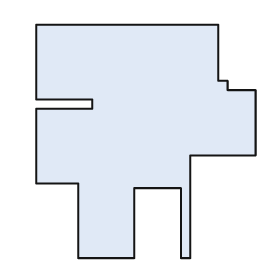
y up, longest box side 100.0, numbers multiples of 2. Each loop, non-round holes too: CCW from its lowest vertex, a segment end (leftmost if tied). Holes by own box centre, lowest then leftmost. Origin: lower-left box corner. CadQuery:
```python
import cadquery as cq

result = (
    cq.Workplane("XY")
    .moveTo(18.0, 0.0)
    .lineTo(42.0, 0.0)
    .lineTo(42.0, 30.0)
    .lineTo(62.0, 30.0)
    .lineTo(62.0, 0.0)
    .lineTo(66.0, 0.0)
    .lineTo(66.0, 44.0)
    .lineTo(94.0, 44.0)
    .lineTo(94.0, 72.0)
    .lineTo(82.0, 72.0)
    .lineTo(82.0, 76.0)
    .lineTo(78.0, 76.0)
    .lineTo(78.0, 100.0)
    .lineTo(0.0, 100.0)
    .lineTo(0.0, 68.0)
    .lineTo(24.0, 68.0)
    .lineTo(24.0, 64.0)
    .lineTo(0.0, 64.0)
    .lineTo(0.0, 32.0)
    .lineTo(18.0, 32.0)
    .close()
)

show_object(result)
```